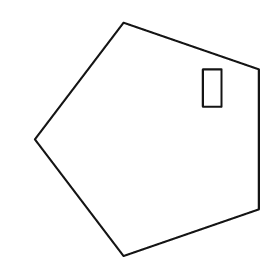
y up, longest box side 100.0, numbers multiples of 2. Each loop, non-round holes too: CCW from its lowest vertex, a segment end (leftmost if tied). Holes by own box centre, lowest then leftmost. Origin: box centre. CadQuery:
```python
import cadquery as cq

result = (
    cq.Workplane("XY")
    .moveTo(-10.0, -50.0)
    .lineTo(48.0, -30.0)
    .lineTo(48.0, 30.0)
    .lineTo(-10.0, 50.0)
    .lineTo(-48.0, 0.0)
    .close()
    .moveTo(24.0, 14.0)
    .lineTo(32.0, 14.0)
    .lineTo(32.0, 30.0)
    .lineTo(24.0, 30.0)
    .close()
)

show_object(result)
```